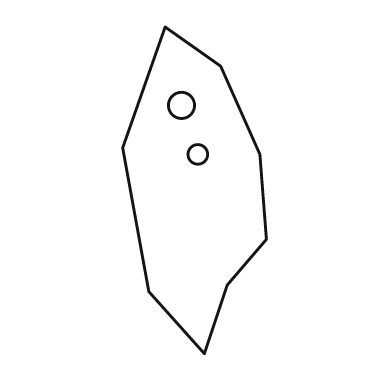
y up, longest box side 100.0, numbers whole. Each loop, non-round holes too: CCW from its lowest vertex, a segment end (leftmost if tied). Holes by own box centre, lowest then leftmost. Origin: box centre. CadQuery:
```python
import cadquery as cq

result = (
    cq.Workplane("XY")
    .moveTo(3.0, -50.0)
    .lineTo(10.0, -29.0)
    .lineTo(22.0, -15.0)
    .lineTo(20.0, 11.0)
    .lineTo(8.0, 38.0)
    .lineTo(-9.0, 50.0)
    .lineTo(-22.0, 13.0)
    .lineTo(-14.0, -31.0)
    .close()
    .moveTo(1.0, 11.0)
    .circle(3.0)
    .moveTo(-4.0, 26.0)
    .circle(4.0)
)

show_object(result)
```